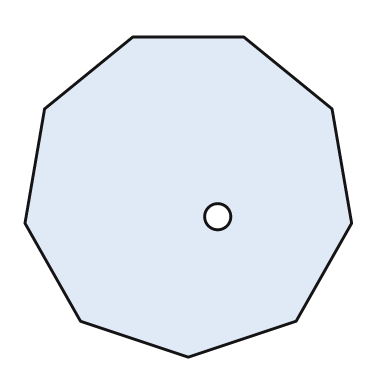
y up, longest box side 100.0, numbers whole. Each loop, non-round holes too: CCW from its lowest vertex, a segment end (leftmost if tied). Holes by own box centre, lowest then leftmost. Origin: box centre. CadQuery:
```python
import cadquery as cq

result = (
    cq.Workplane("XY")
    .moveTo(0.0, -49.0)
    .lineTo(33.0, -38.0)
    .lineTo(50.0, -8.0)
    .lineTo(44.0, 27.0)
    .lineTo(17.0, 49.0)
    .lineTo(-17.0, 49.0)
    .lineTo(-44.0, 27.0)
    .lineTo(-50.0, -8.0)
    .lineTo(-33.0, -38.0)
    .close()
    .moveTo(9.0, -6.0)
    .circle(4.0)
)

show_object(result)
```